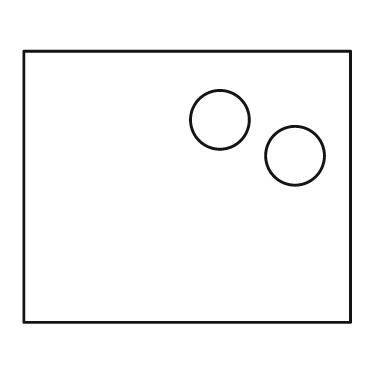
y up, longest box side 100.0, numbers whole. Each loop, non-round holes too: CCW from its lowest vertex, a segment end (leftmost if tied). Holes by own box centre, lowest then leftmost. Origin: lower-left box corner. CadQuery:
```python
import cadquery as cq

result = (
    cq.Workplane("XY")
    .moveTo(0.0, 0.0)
    .lineTo(100.0, 0.0)
    .lineTo(100.0, 83.0)
    .lineTo(0.0, 83.0)
    .close()
    .moveTo(83.0, 51.0)
    .circle(9.0)
    .moveTo(60.0, 62.0)
    .circle(9.0)
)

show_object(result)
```